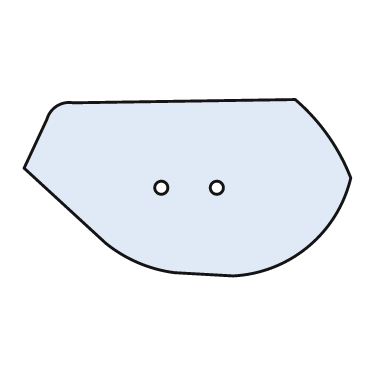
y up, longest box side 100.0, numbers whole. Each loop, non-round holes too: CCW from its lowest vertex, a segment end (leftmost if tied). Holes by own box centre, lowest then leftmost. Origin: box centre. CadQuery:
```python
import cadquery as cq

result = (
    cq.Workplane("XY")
    .moveTo(14.0, -27.0)
    .threePointArc((37.0, -18.0), (50.0, 3.0))
    .threePointArc((43.0, 16.0), (33.0, 27.0))
    .lineTo(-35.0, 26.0)
    .threePointArc((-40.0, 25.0), (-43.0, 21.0))
    .lineTo(-50.0, 6.0)
    .lineTo(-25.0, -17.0)
    .threePointArc((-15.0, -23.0), (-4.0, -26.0))
    .close()
    .moveTo(-8.0, 0.0)
    .circle(2.0)
    .moveTo(9.0, 0.0)
    .circle(2.0)
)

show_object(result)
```